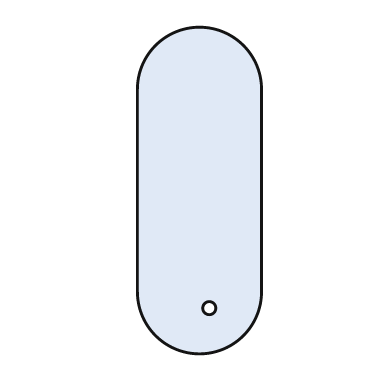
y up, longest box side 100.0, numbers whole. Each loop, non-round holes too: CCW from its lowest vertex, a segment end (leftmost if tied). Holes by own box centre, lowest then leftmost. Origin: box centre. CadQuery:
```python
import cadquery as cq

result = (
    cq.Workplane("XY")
    .moveTo(-19.0, -31.0)
    .threePointArc((0.0, -50.0), (19.0, -31.0))
    .lineTo(19.0, 31.0)
    .threePointArc((0.0, 50.0), (-19.0, 31.0))
    .close()
    .moveTo(3.0, -36.0)
    .circle(2.0)
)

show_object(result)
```